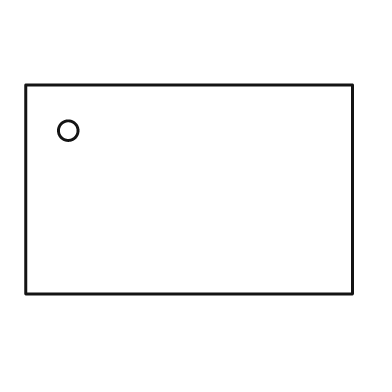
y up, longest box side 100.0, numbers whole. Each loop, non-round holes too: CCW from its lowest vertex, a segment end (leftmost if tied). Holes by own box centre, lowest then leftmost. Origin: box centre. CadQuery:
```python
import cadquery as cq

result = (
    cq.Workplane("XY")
    .moveTo(-50.0, -32.0)
    .lineTo(50.0, -32.0)
    .lineTo(50.0, 32.0)
    .lineTo(-50.0, 32.0)
    .close()
    .moveTo(-37.0, 18.0)
    .circle(3.0)
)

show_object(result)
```